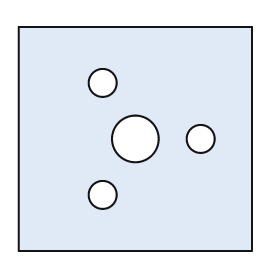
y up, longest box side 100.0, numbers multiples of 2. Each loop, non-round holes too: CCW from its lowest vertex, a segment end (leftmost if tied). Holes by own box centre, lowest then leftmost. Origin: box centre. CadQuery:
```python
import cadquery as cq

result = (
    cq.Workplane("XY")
    .moveTo(-50.0, -48.0)
    .lineTo(50.0, -48.0)
    .lineTo(50.0, 48.0)
    .lineTo(-50.0, 48.0)
    .close()
    .moveTo(-14.0, -24.0)
    .circle(6.0)
    .moveTo(0.0, 0.0)
    .circle(10.0)
    .moveTo(28.0, 0.0)
    .circle(6.0)
    .moveTo(-14.0, 24.0)
    .circle(6.0)
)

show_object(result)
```